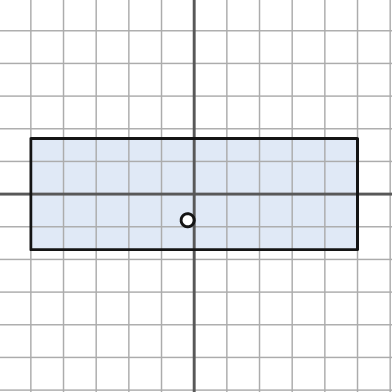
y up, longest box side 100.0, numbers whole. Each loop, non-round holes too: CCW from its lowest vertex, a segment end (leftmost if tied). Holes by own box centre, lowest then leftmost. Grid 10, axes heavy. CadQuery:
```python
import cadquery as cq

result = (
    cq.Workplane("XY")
    .moveTo(-50.0, -17.0)
    .lineTo(50.0, -17.0)
    .lineTo(50.0, 17.0)
    .lineTo(-50.0, 17.0)
    .close()
    .moveTo(-2.0, -8.0)
    .circle(2.0)
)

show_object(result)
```